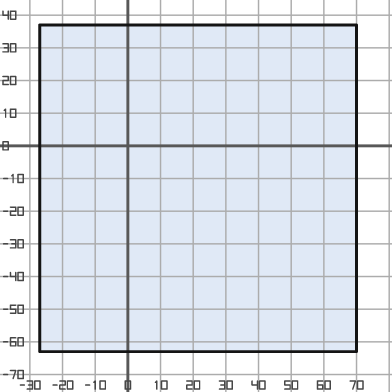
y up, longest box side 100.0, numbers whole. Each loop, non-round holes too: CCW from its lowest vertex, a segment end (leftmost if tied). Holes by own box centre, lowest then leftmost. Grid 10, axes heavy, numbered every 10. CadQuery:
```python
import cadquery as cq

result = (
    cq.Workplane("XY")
    .moveTo(-27.0, -63.0)
    .lineTo(70.0, -63.0)
    .lineTo(70.0, 37.0)
    .lineTo(-27.0, 37.0)
    .close()
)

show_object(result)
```